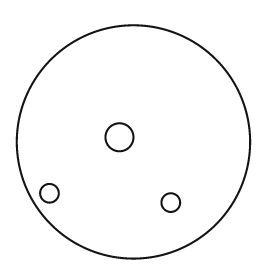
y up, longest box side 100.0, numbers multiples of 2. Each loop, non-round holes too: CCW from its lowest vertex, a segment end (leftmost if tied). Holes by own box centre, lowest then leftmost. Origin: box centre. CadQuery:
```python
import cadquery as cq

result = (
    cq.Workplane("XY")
    .moveTo(0.0, 0.0)
    .circle(50.0)
    .moveTo(16.0, -26.0)
    .circle(4.0)
    .moveTo(-36.0, -22.0)
    .circle(4.0)
    .moveTo(-6.0, 2.0)
    .circle(6.0)
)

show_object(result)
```